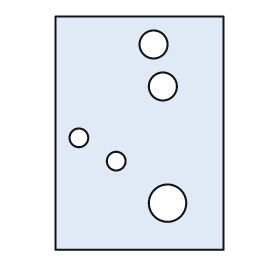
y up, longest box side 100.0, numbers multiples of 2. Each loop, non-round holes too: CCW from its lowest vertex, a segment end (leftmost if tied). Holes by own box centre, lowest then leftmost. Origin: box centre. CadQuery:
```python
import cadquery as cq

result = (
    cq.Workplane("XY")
    .moveTo(-36.0, -50.0)
    .lineTo(36.0, -50.0)
    .lineTo(36.0, 50.0)
    .lineTo(-36.0, 50.0)
    .close()
    .moveTo(12.0, -30.0)
    .circle(8.0)
    .moveTo(-10.0, -12.0)
    .circle(4.0)
    .moveTo(-26.0, -2.0)
    .circle(4.0)
    .moveTo(10.0, 20.0)
    .circle(6.0)
    .moveTo(6.0, 38.0)
    .circle(6.0)
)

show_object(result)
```